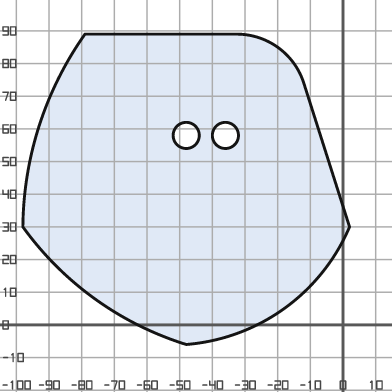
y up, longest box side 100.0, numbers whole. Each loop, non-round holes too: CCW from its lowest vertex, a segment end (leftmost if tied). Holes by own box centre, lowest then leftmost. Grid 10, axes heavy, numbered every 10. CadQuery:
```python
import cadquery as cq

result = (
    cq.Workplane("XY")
    .moveTo(-48.0, -6.0)
    .threePointArc((-18.0, 5.0), (2.0, 30.0))
    .lineTo(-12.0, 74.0)
    .threePointArc((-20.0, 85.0), (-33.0, 89.0))
    .lineTo(-79.0, 89.0)
    .threePointArc((-93.0, 61.0), (-98.0, 30.0))
    .threePointArc((-76.0, 8.0), (-48.0, -6.0))
    .close()
    .moveTo(-48.0, 58.0)
    .circle(4.0)
    .moveTo(-36.0, 58.0)
    .circle(4.0)
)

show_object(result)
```